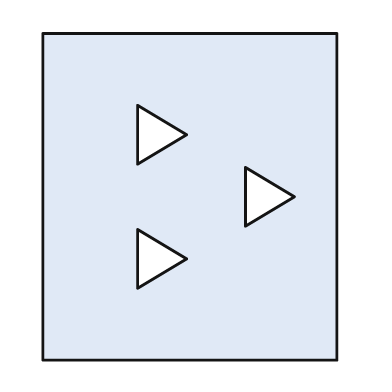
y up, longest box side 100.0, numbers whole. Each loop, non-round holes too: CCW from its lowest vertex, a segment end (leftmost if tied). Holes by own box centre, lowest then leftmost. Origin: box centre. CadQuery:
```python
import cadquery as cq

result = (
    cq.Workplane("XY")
    .moveTo(-45.0, -50.0)
    .lineTo(45.0, -50.0)
    .lineTo(45.0, 50.0)
    .lineTo(-45.0, 50.0)
    .close()
    .moveTo(-16.0, -28.0)
    .lineTo(-1.0, -19.0)
    .lineTo(-16.0, -10.0)
    .close()
    .moveTo(17.0, -9.0)
    .lineTo(32.0, 0.0)
    .lineTo(17.0, 9.0)
    .close()
    .moveTo(-16.0, 10.0)
    .lineTo(-1.0, 19.0)
    .lineTo(-16.0, 28.0)
    .close()
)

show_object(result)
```